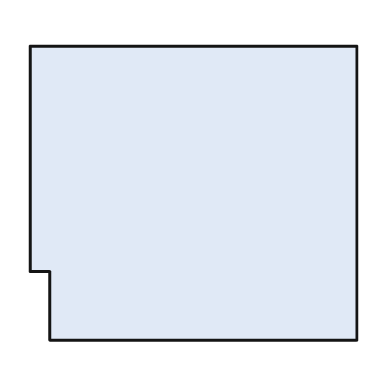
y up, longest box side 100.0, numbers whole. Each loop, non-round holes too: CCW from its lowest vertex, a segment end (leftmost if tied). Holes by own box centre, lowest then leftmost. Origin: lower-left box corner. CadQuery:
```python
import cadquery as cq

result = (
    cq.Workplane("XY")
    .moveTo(6.0, 0.0)
    .lineTo(100.0, 0.0)
    .lineTo(100.0, 90.0)
    .lineTo(0.0, 90.0)
    .lineTo(0.0, 21.0)
    .lineTo(6.0, 21.0)
    .close()
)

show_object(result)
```